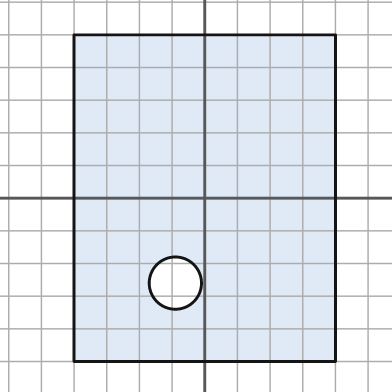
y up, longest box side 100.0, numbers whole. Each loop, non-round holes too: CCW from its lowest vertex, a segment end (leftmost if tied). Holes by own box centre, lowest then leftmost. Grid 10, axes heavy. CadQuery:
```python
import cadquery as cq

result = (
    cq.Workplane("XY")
    .moveTo(-40.0, -50.0)
    .lineTo(40.0, -50.0)
    .lineTo(40.0, 50.0)
    .lineTo(-40.0, 50.0)
    .close()
    .moveTo(-9.0, -26.0)
    .circle(8.0)
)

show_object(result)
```